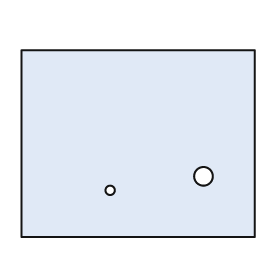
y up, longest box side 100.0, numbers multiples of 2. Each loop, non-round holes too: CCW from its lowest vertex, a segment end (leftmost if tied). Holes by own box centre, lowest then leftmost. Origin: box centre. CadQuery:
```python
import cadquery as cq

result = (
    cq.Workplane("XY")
    .moveTo(-50.0, -40.0)
    .lineTo(50.0, -40.0)
    .lineTo(50.0, 40.0)
    .lineTo(-50.0, 40.0)
    .close()
    .moveTo(-12.0, -20.0)
    .circle(2.0)
    .moveTo(28.0, -14.0)
    .circle(4.0)
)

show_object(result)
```